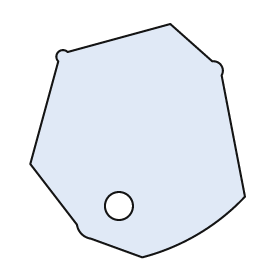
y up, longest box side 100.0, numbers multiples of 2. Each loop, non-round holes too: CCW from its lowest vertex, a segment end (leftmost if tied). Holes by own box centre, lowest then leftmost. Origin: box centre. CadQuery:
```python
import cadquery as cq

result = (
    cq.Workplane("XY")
    .moveTo(2.0, -50.0)
    .threePointArc((26.0, -40.0), (46.0, -24.0))
    .lineTo(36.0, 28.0)
    .threePointArc((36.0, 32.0), (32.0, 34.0))
    .lineTo(14.0, 50.0)
    .lineTo(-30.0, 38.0)
    .threePointArc((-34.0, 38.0), (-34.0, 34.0))
    .lineTo(-46.0, -10.0)
    .lineTo(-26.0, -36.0)
    .threePointArc((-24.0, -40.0), (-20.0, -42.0))
    .close()
    .moveTo(-8.0, -28.0)
    .circle(6.0)
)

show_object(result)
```